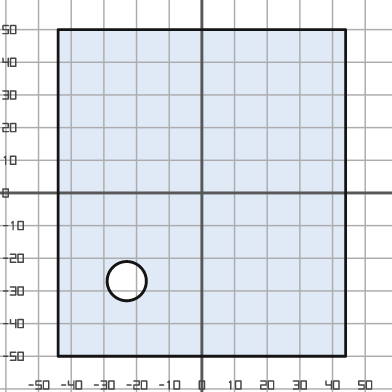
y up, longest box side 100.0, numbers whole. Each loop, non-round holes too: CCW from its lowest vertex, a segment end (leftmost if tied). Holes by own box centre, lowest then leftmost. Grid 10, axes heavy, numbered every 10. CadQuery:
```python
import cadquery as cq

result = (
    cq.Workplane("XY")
    .moveTo(-44.0, -50.0)
    .lineTo(44.0, -50.0)
    .lineTo(44.0, 50.0)
    .lineTo(-44.0, 50.0)
    .close()
    .moveTo(-23.0, -27.0)
    .circle(6.0)
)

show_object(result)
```